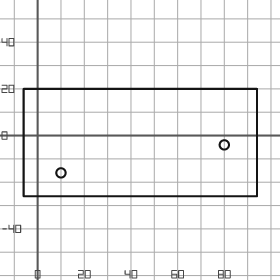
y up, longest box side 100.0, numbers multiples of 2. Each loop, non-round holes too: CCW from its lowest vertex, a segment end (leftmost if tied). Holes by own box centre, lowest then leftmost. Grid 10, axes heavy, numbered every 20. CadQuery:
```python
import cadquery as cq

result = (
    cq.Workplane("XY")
    .moveTo(-6.0, -26.0)
    .lineTo(94.0, -26.0)
    .lineTo(94.0, 20.0)
    .lineTo(-6.0, 20.0)
    .close()
    .moveTo(10.0, -16.0)
    .circle(2.0)
    .moveTo(80.0, -4.0)
    .circle(2.0)
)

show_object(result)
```